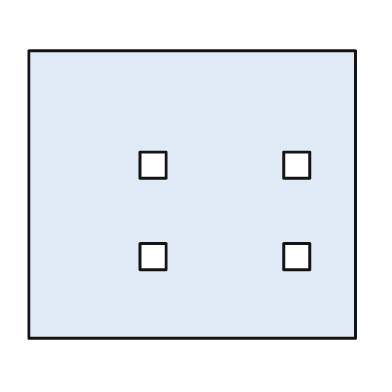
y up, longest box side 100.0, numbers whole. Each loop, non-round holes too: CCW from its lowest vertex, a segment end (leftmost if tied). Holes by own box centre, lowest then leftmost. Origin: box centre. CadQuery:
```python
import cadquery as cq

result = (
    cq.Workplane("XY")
    .moveTo(-50.0, -44.0)
    .lineTo(50.0, -44.0)
    .lineTo(50.0, 44.0)
    .lineTo(-50.0, 44.0)
    .close()
    .moveTo(-16.0, -23.0)
    .lineTo(-8.0, -23.0)
    .lineTo(-8.0, -15.0)
    .lineTo(-16.0, -15.0)
    .close()
    .moveTo(28.0, -23.0)
    .lineTo(36.0, -23.0)
    .lineTo(36.0, -15.0)
    .lineTo(28.0, -15.0)
    .close()
    .moveTo(-16.0, 5.0)
    .lineTo(-8.0, 5.0)
    .lineTo(-8.0, 13.0)
    .lineTo(-16.0, 13.0)
    .close()
    .moveTo(28.0, 5.0)
    .lineTo(36.0, 5.0)
    .lineTo(36.0, 13.0)
    .lineTo(28.0, 13.0)
    .close()
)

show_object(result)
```